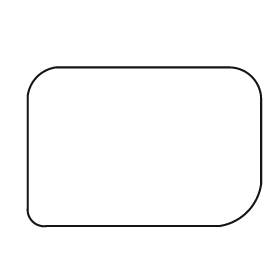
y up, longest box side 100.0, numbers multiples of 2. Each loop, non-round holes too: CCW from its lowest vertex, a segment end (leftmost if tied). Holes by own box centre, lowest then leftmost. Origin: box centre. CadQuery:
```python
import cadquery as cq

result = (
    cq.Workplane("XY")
    .moveTo(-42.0, -34.0)
    .lineTo(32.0, -34.0)
    .threePointArc((44.0, -28.0), (50.0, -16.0))
    .lineTo(50.0, 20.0)
    .threePointArc((46.0, 30.0), (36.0, 34.0))
    .lineTo(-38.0, 34.0)
    .threePointArc((-46.0, 30.0), (-50.0, 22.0))
    .lineTo(-50.0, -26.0)
    .threePointArc((-48.0, -32.0), (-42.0, -34.0))
    .close()
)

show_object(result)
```